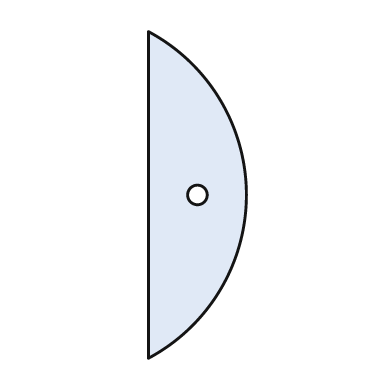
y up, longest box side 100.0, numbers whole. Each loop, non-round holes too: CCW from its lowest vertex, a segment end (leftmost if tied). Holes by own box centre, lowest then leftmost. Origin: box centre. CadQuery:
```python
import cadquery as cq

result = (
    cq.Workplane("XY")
    .moveTo(-15.0, -50.0)
    .threePointArc((15.0, 0.0), (-15.0, 50.0))
    .close()
    .moveTo(0.0, 0.0)
    .circle(3.0)
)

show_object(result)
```